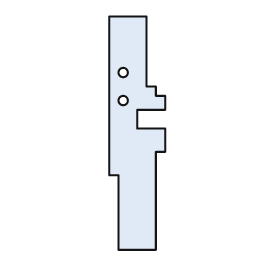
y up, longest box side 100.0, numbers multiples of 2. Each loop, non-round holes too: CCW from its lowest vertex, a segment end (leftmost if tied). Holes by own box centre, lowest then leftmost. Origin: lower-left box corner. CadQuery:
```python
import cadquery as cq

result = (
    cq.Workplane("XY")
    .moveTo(4.0, 0.0)
    .lineTo(20.0, 0.0)
    .lineTo(20.0, 42.0)
    .lineTo(24.0, 42.0)
    .lineTo(24.0, 52.0)
    .lineTo(12.0, 52.0)
    .lineTo(12.0, 60.0)
    .lineTo(24.0, 60.0)
    .lineTo(24.0, 66.0)
    .lineTo(20.0, 66.0)
    .lineTo(20.0, 70.0)
    .lineTo(16.0, 70.0)
    .lineTo(16.0, 100.0)
    .lineTo(0.0, 100.0)
    .lineTo(0.0, 32.0)
    .lineTo(4.0, 32.0)
    .close()
    .moveTo(6.0, 64.0)
    .circle(2.0)
    .moveTo(6.0, 76.0)
    .circle(2.0)
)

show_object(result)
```